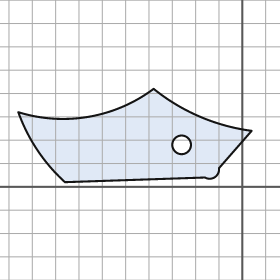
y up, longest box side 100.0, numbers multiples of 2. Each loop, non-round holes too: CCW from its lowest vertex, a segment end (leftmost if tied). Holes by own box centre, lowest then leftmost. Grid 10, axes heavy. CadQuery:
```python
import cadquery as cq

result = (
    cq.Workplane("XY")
    .moveTo(-76.0, 2.0)
    .lineTo(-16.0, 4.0)
    .threePointArc((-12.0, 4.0), (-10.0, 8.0))
    .lineTo(4.0, 24.0)
    .threePointArc((-18.0, 30.0), (-38.0, 42.0))
    .threePointArc((-66.0, 30.0), (-96.0, 32.0))
    .threePointArc((-88.0, 16.0), (-76.0, 2.0))
    .close()
    .moveTo(-26.0, 18.0)
    .circle(4.0)
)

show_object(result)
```